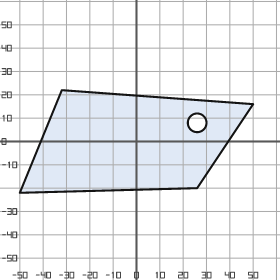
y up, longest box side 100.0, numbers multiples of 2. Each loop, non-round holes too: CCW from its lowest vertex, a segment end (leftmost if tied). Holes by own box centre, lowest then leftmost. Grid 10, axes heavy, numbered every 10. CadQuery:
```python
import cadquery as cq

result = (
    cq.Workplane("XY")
    .moveTo(-50.0, -22.0)
    .lineTo(26.0, -20.0)
    .lineTo(50.0, 16.0)
    .lineTo(-32.0, 22.0)
    .close()
    .moveTo(26.0, 8.0)
    .circle(4.0)
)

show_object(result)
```